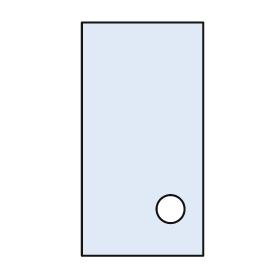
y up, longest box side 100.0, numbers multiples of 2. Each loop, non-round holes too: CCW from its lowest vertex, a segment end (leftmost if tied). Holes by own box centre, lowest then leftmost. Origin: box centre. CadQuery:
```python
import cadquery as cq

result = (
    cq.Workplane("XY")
    .moveTo(-26.0, -50.0)
    .lineTo(26.0, -50.0)
    .lineTo(26.0, 50.0)
    .lineTo(-26.0, 50.0)
    .close()
    .moveTo(12.0, -30.0)
    .circle(6.0)
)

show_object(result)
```